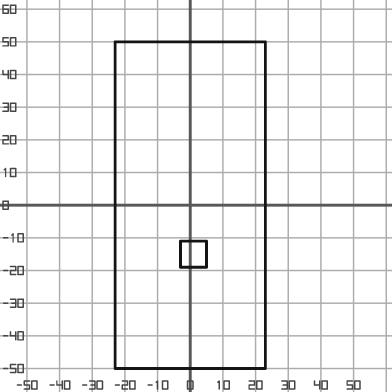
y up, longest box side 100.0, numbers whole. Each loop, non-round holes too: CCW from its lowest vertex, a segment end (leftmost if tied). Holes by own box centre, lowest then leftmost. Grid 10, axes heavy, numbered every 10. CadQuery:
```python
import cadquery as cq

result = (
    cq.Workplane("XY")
    .moveTo(-23.0, -50.0)
    .lineTo(23.0, -50.0)
    .lineTo(23.0, 50.0)
    .lineTo(-23.0, 50.0)
    .close()
    .moveTo(-3.0, -19.0)
    .lineTo(5.0, -19.0)
    .lineTo(5.0, -11.0)
    .lineTo(-3.0, -11.0)
    .close()
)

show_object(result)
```